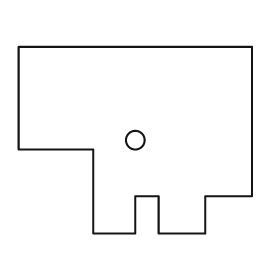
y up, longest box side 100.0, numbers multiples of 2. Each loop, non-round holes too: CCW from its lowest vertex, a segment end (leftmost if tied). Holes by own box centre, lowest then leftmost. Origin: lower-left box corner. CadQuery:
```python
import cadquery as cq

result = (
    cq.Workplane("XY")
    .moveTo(32.0, 0.0)
    .lineTo(50.0, 0.0)
    .lineTo(50.0, 16.0)
    .lineTo(60.0, 16.0)
    .lineTo(60.0, 0.0)
    .lineTo(80.0, 0.0)
    .lineTo(80.0, 16.0)
    .lineTo(100.0, 16.0)
    .lineTo(100.0, 80.0)
    .lineTo(0.0, 80.0)
    .lineTo(0.0, 36.0)
    .lineTo(32.0, 36.0)
    .close()
    .moveTo(50.0, 40.0)
    .circle(4.0)
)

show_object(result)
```